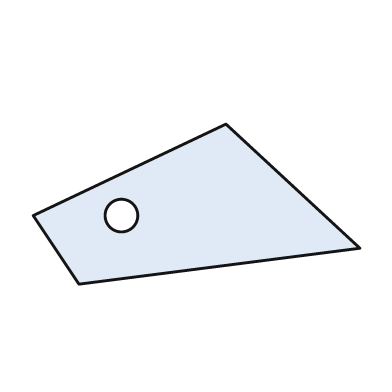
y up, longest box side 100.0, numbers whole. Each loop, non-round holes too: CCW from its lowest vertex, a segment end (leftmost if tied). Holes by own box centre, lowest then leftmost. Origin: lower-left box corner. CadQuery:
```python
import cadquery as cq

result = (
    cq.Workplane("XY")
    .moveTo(14.0, 0.0)
    .lineTo(100.0, 11.0)
    .lineTo(59.0, 49.0)
    .lineTo(0.0, 21.0)
    .close()
    .moveTo(27.0, 21.0)
    .circle(5.0)
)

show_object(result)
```